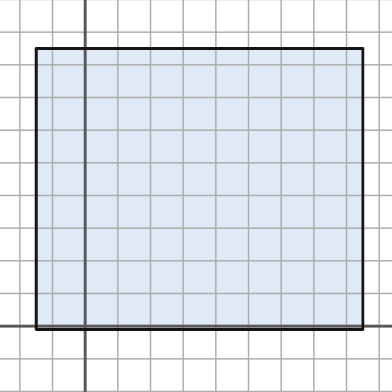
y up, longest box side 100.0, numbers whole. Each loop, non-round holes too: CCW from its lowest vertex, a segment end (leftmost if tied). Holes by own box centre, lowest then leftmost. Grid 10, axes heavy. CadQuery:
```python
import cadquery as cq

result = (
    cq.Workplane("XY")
    .moveTo(-15.0, -1.0)
    .lineTo(85.0, -1.0)
    .lineTo(85.0, 85.0)
    .lineTo(-15.0, 85.0)
    .close()
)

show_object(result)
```